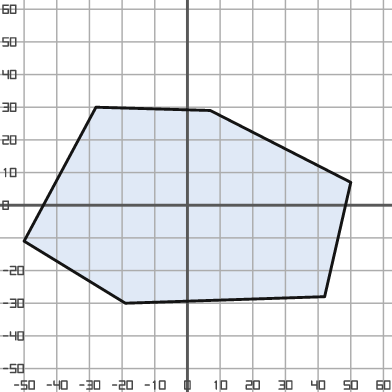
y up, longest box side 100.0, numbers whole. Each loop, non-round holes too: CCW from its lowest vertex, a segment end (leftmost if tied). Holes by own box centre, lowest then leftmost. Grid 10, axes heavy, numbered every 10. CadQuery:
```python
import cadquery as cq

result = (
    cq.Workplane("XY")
    .moveTo(-19.0, -30.0)
    .lineTo(42.0, -28.0)
    .lineTo(50.0, 7.0)
    .lineTo(7.0, 29.0)
    .lineTo(-28.0, 30.0)
    .lineTo(-50.0, -11.0)
    .close()
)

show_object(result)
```